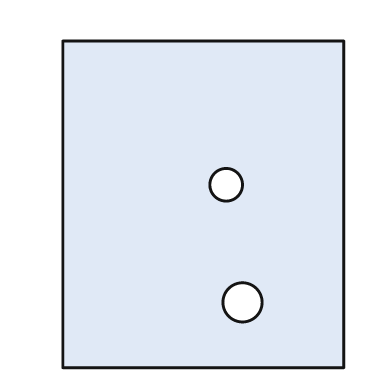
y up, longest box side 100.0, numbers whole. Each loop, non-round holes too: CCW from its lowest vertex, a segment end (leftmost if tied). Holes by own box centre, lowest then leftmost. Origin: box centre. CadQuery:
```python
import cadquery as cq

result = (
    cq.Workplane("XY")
    .moveTo(-43.0, -50.0)
    .lineTo(43.0, -50.0)
    .lineTo(43.0, 50.0)
    .lineTo(-43.0, 50.0)
    .close()
    .moveTo(12.0, -30.0)
    .circle(6.0)
    .moveTo(7.0, 6.0)
    .circle(5.0)
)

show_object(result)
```